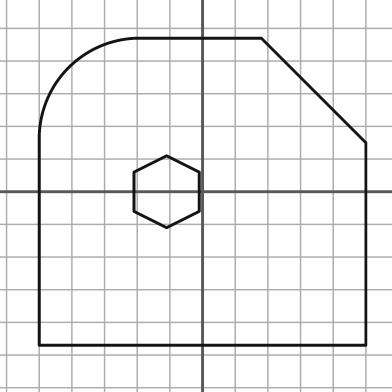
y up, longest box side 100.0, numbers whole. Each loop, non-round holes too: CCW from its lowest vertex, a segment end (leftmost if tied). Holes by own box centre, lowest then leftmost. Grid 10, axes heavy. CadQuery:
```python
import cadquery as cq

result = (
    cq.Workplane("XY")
    .moveTo(-50.0, -47.0)
    .lineTo(50.0, -47.0)
    .lineTo(50.0, 15.0)
    .lineTo(18.0, 47.0)
    .lineTo(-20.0, 47.0)
    .threePointArc((-41.0, 38.0), (-50.0, 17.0))
    .close()
    .moveTo(-11.0, -11.0)
    .lineTo(-1.0, -6.0)
    .lineTo(-1.0, 6.0)
    .lineTo(-11.0, 11.0)
    .lineTo(-21.0, 6.0)
    .lineTo(-21.0, -6.0)
    .close()
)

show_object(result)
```